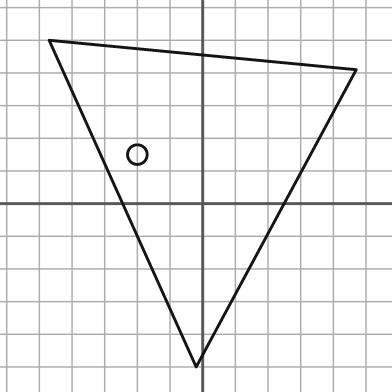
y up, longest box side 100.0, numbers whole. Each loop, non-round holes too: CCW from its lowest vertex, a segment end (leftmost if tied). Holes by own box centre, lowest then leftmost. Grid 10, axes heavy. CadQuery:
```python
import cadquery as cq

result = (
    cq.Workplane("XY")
    .moveTo(-2.0, -50.0)
    .lineTo(47.0, 41.0)
    .lineTo(-47.0, 50.0)
    .close()
    .moveTo(-20.0, 15.0)
    .circle(3.0)
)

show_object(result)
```